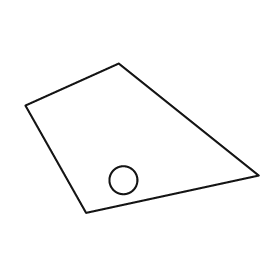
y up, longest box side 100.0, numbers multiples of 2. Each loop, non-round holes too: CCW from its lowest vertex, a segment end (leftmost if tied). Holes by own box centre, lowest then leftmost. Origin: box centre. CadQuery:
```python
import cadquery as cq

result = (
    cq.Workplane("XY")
    .moveTo(-24.0, -32.0)
    .lineTo(50.0, -16.0)
    .lineTo(-10.0, 32.0)
    .lineTo(-50.0, 14.0)
    .close()
    .moveTo(-8.0, -18.0)
    .circle(6.0)
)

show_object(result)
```